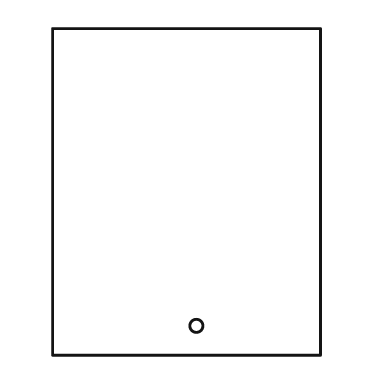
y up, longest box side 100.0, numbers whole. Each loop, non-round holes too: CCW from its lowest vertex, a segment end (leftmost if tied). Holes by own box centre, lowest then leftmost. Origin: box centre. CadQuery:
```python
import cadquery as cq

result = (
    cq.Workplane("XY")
    .moveTo(-41.0, -50.0)
    .lineTo(41.0, -50.0)
    .lineTo(41.0, 50.0)
    .lineTo(-41.0, 50.0)
    .close()
    .moveTo(3.0, -41.0)
    .circle(2.0)
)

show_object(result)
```